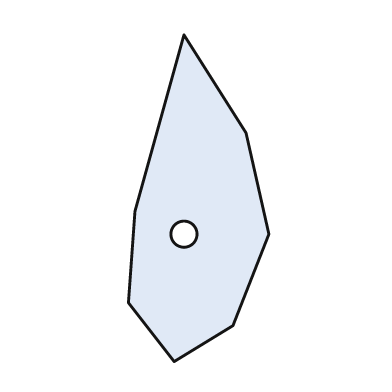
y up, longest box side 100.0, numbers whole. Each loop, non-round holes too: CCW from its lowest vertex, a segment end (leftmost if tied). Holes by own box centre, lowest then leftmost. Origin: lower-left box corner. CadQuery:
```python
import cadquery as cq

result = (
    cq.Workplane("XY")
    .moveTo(14.0, 0.0)
    .lineTo(32.0, 11.0)
    .lineTo(43.0, 39.0)
    .lineTo(36.0, 70.0)
    .lineTo(17.0, 100.0)
    .lineTo(2.0, 46.0)
    .lineTo(0.0, 18.0)
    .close()
    .moveTo(17.0, 39.0)
    .circle(4.0)
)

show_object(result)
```